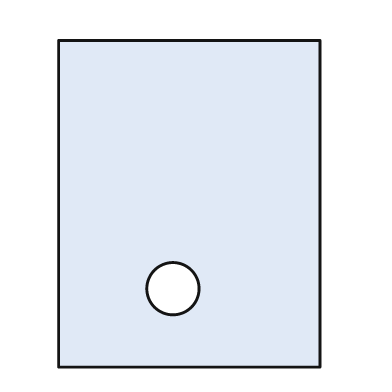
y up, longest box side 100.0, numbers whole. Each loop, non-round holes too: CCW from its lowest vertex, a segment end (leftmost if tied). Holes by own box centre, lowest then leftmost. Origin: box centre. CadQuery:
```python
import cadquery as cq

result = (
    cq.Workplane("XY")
    .moveTo(-40.0, -50.0)
    .lineTo(40.0, -50.0)
    .lineTo(40.0, 50.0)
    .lineTo(-40.0, 50.0)
    .close()
    .moveTo(-5.0, -26.0)
    .circle(8.0)
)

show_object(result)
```